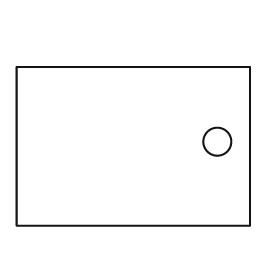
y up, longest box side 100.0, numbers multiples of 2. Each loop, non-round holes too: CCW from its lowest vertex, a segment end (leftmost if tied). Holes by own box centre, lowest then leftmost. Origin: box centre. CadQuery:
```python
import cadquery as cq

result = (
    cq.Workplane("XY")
    .moveTo(-50.0, -34.0)
    .lineTo(50.0, -34.0)
    .lineTo(50.0, 34.0)
    .lineTo(-50.0, 34.0)
    .close()
    .moveTo(36.0, 2.0)
    .circle(6.0)
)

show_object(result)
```